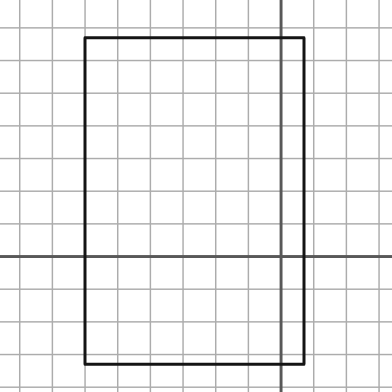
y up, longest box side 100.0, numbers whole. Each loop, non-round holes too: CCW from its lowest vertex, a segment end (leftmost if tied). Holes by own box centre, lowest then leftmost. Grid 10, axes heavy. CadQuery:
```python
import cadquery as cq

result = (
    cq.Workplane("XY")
    .moveTo(-60.0, -33.0)
    .lineTo(7.0, -33.0)
    .lineTo(7.0, 67.0)
    .lineTo(-60.0, 67.0)
    .close()
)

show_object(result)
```